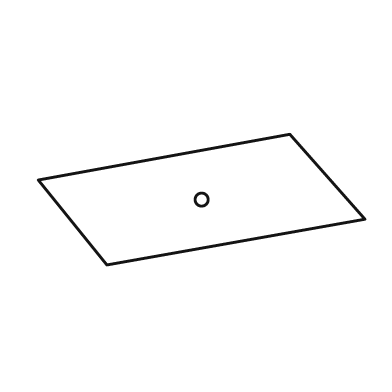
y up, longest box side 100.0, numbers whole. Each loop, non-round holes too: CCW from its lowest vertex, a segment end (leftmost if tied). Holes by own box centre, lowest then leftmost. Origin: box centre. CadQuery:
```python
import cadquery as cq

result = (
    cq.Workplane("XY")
    .moveTo(-29.0, -20.0)
    .lineTo(50.0, -6.0)
    .lineTo(27.0, 20.0)
    .lineTo(-50.0, 6.0)
    .close()
    .moveTo(0.0, 0.0)
    .circle(2.0)
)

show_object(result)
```